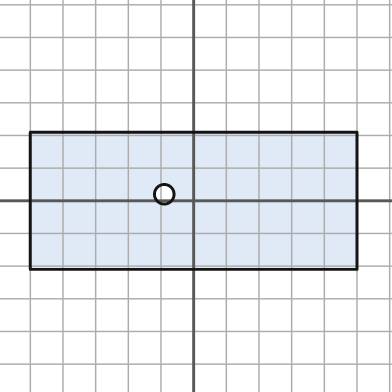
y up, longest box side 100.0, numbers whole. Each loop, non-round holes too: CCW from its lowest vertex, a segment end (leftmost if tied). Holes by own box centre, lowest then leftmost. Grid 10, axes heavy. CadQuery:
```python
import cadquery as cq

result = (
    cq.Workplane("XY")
    .moveTo(-50.0, -21.0)
    .lineTo(50.0, -21.0)
    .lineTo(50.0, 21.0)
    .lineTo(-50.0, 21.0)
    .close()
    .moveTo(-9.0, 2.0)
    .circle(3.0)
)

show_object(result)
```